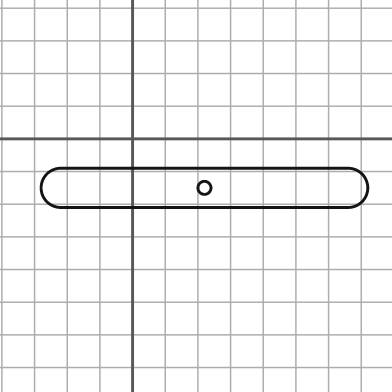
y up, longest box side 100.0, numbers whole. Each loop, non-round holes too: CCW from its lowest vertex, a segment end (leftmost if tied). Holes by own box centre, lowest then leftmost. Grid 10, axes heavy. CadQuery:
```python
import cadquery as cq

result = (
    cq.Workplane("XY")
    .moveTo(-22.0, -21.0)
    .lineTo(66.0, -21.0)
    .threePointArc((72.0, -15.0), (66.0, -9.0))
    .lineTo(-22.0, -9.0)
    .threePointArc((-28.0, -15.0), (-22.0, -21.0))
    .close()
    .moveTo(22.0, -15.0)
    .circle(2.0)
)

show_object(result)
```